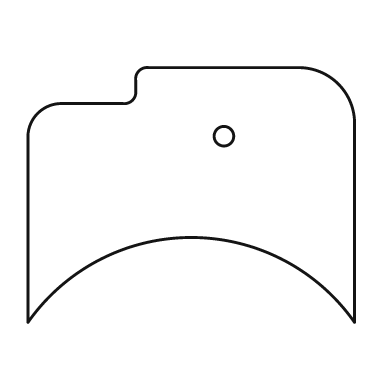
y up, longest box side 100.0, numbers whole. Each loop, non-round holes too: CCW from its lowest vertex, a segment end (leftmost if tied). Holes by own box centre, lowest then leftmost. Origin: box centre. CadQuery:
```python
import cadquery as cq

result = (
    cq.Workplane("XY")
    .moveTo(-50.0, -39.0)
    .threePointArc((0.0, -13.0), (50.0, -39.0))
    .lineTo(50.0, 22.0)
    .threePointArc((45.0, 34.0), (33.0, 39.0))
    .lineTo(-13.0, 39.0)
    .threePointArc((-16.0, 38.0), (-17.0, 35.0))
    .lineTo(-17.0, 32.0)
    .threePointArc((-18.0, 29.0), (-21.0, 28.0))
    .lineTo(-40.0, 28.0)
    .threePointArc((-47.0, 25.0), (-50.0, 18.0))
    .close()
    .moveTo(10.0, 18.0)
    .circle(3.0)
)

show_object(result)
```